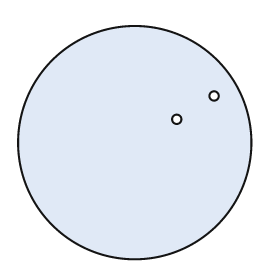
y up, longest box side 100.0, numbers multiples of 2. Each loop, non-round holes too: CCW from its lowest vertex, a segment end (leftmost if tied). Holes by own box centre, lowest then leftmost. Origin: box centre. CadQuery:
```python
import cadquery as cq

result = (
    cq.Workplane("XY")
    .moveTo(0.0, 0.0)
    .circle(50.0)
    .moveTo(18.0, 10.0)
    .circle(2.0)
    .moveTo(34.0, 20.0)
    .circle(2.0)
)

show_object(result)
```